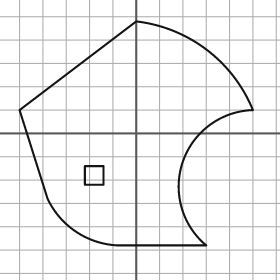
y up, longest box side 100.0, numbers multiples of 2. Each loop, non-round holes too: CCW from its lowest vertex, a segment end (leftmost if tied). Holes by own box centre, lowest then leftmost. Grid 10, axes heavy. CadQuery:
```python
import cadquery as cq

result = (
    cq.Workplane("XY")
    .moveTo(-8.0, -48.0)
    .lineTo(30.0, -48.0)
    .threePointArc((20.0, -12.0), (50.0, 10.0))
    .threePointArc((30.0, 36.0), (0.0, 48.0))
    .lineTo(-50.0, 10.0)
    .lineTo(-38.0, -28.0)
    .threePointArc((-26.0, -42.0), (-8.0, -48.0))
    .close()
    .moveTo(-22.0, -22.0)
    .lineTo(-14.0, -22.0)
    .lineTo(-14.0, -14.0)
    .lineTo(-22.0, -14.0)
    .close()
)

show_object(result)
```